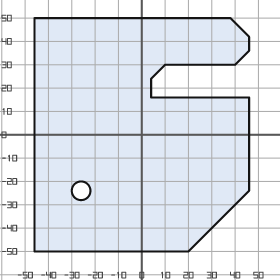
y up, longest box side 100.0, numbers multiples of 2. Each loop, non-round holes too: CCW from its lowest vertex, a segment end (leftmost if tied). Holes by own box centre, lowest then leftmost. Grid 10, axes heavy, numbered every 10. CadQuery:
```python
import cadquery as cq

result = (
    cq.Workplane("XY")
    .moveTo(-46.0, -50.0)
    .lineTo(20.0, -50.0)
    .lineTo(46.0, -24.0)
    .lineTo(46.0, 16.0)
    .lineTo(4.0, 16.0)
    .lineTo(4.0, 24.0)
    .lineTo(10.0, 30.0)
    .lineTo(40.0, 30.0)
    .lineTo(46.0, 36.0)
    .lineTo(46.0, 42.0)
    .lineTo(38.0, 50.0)
    .lineTo(-46.0, 50.0)
    .close()
    .moveTo(-26.0, -24.0)
    .circle(4.0)
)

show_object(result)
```